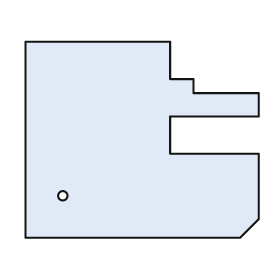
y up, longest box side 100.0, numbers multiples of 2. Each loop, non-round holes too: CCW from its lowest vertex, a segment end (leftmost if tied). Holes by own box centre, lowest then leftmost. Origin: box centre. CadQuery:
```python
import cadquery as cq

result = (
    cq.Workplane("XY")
    .moveTo(-50.0, -42.0)
    .lineTo(42.0, -42.0)
    .lineTo(50.0, -34.0)
    .lineTo(50.0, -6.0)
    .lineTo(12.0, -6.0)
    .lineTo(12.0, 10.0)
    .lineTo(50.0, 10.0)
    .lineTo(50.0, 20.0)
    .lineTo(22.0, 20.0)
    .lineTo(22.0, 26.0)
    .lineTo(12.0, 26.0)
    .lineTo(12.0, 42.0)
    .lineTo(-50.0, 42.0)
    .close()
    .moveTo(-34.0, -24.0)
    .circle(2.0)
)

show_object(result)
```